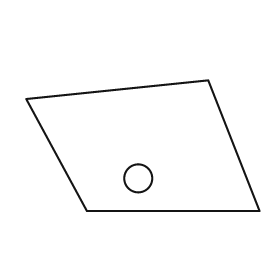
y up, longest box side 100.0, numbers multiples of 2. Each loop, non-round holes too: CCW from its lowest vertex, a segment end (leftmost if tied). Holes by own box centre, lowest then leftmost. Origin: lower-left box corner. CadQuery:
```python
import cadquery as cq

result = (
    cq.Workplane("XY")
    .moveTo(26.0, 0.0)
    .lineTo(100.0, 0.0)
    .lineTo(78.0, 56.0)
    .lineTo(0.0, 48.0)
    .close()
    .moveTo(48.0, 14.0)
    .circle(6.0)
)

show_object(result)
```